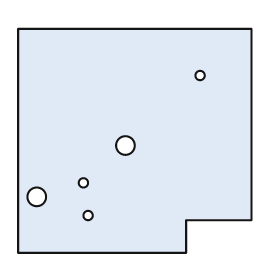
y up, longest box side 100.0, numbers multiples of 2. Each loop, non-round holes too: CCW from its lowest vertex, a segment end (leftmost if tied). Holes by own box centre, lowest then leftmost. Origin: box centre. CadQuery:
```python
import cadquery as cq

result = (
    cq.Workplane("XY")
    .moveTo(-50.0, -48.0)
    .lineTo(22.0, -48.0)
    .lineTo(22.0, -34.0)
    .lineTo(50.0, -34.0)
    .lineTo(50.0, 48.0)
    .lineTo(-50.0, 48.0)
    .close()
    .moveTo(-20.0, -32.0)
    .circle(2.0)
    .moveTo(-42.0, -24.0)
    .circle(4.0)
    .moveTo(-22.0, -18.0)
    .circle(2.0)
    .moveTo(-4.0, -2.0)
    .circle(4.0)
    .moveTo(28.0, 28.0)
    .circle(2.0)
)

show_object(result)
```